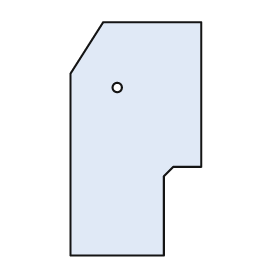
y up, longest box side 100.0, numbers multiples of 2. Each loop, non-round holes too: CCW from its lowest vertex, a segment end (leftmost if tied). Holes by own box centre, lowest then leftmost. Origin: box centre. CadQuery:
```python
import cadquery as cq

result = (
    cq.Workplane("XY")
    .moveTo(-28.0, -50.0)
    .lineTo(12.0, -50.0)
    .lineTo(12.0, -16.0)
    .lineTo(16.0, -12.0)
    .lineTo(28.0, -12.0)
    .lineTo(28.0, 50.0)
    .lineTo(-14.0, 50.0)
    .lineTo(-28.0, 28.0)
    .close()
    .moveTo(-8.0, 22.0)
    .circle(2.0)
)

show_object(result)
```